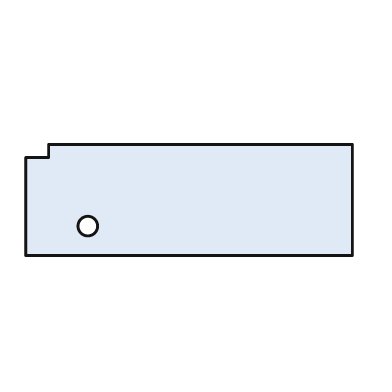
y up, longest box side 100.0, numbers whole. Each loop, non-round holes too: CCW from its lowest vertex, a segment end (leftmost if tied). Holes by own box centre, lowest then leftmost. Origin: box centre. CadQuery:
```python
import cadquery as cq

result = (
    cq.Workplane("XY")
    .moveTo(-50.0, -17.0)
    .lineTo(50.0, -17.0)
    .lineTo(50.0, 17.0)
    .lineTo(-43.0, 17.0)
    .lineTo(-43.0, 13.0)
    .lineTo(-50.0, 13.0)
    .close()
    .moveTo(-31.0, -8.0)
    .circle(3.0)
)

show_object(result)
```